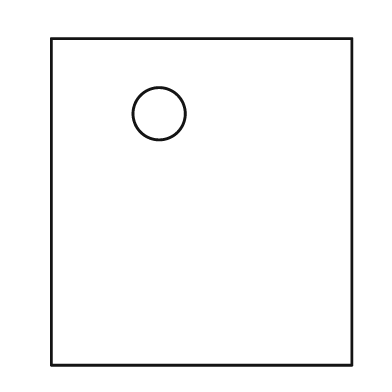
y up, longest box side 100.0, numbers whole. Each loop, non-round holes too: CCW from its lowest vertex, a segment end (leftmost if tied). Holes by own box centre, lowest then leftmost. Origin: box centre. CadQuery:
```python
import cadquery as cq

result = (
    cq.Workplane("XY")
    .moveTo(-46.0, -50.0)
    .lineTo(46.0, -50.0)
    .lineTo(46.0, 50.0)
    .lineTo(-46.0, 50.0)
    .close()
    .moveTo(-13.0, 27.0)
    .circle(8.0)
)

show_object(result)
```